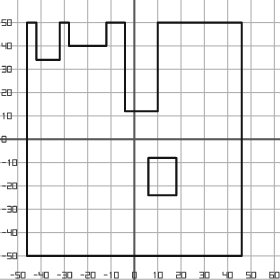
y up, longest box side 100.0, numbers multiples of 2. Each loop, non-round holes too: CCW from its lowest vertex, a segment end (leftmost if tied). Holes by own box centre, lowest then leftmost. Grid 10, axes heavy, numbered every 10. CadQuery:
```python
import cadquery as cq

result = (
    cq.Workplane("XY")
    .moveTo(-46.0, -50.0)
    .lineTo(46.0, -50.0)
    .lineTo(46.0, 50.0)
    .lineTo(10.0, 50.0)
    .lineTo(10.0, 12.0)
    .lineTo(-4.0, 12.0)
    .lineTo(-4.0, 50.0)
    .lineTo(-12.0, 50.0)
    .lineTo(-12.0, 40.0)
    .lineTo(-28.0, 40.0)
    .lineTo(-28.0, 50.0)
    .lineTo(-32.0, 50.0)
    .lineTo(-32.0, 34.0)
    .lineTo(-42.0, 34.0)
    .lineTo(-42.0, 50.0)
    .lineTo(-46.0, 50.0)
    .close()
    .moveTo(6.0, -24.0)
    .lineTo(18.0, -24.0)
    .lineTo(18.0, -8.0)
    .lineTo(6.0, -8.0)
    .close()
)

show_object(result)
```